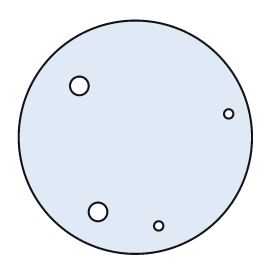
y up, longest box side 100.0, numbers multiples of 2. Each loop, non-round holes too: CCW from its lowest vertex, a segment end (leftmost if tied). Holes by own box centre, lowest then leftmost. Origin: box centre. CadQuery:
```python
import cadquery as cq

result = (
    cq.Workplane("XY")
    .moveTo(0.0, 0.0)
    .circle(50.0)
    .moveTo(10.0, -38.0)
    .circle(2.0)
    .moveTo(-16.0, -32.0)
    .circle(4.0)
    .moveTo(40.0, 10.0)
    .circle(2.0)
    .moveTo(-24.0, 22.0)
    .circle(4.0)
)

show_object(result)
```